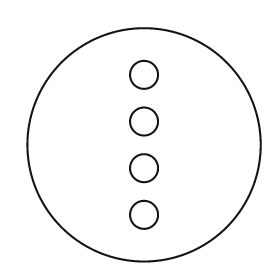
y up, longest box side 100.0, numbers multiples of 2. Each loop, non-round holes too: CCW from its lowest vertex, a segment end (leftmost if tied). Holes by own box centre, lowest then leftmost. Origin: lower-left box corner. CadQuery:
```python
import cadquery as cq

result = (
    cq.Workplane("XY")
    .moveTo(50.0, 50.0)
    .circle(50.0)
    .moveTo(50.0, 20.0)
    .circle(6.0)
    .moveTo(50.0, 40.0)
    .circle(6.0)
    .moveTo(50.0, 60.0)
    .circle(6.0)
    .moveTo(50.0, 80.0)
    .circle(6.0)
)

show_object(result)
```